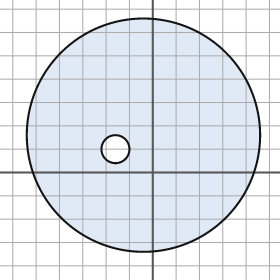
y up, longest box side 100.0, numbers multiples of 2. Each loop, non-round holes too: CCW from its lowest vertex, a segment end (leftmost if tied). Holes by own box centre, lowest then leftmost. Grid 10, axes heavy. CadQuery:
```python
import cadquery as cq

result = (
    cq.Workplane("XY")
    .moveTo(-4.0, 16.0)
    .circle(50.0)
    .moveTo(-16.0, 10.0)
    .circle(6.0)
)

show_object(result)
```